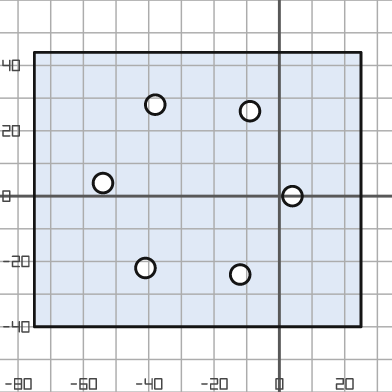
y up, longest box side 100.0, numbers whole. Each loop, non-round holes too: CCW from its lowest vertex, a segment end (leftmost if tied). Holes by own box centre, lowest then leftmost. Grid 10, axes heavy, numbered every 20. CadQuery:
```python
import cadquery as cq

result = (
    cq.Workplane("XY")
    .moveTo(-75.0, -40.0)
    .lineTo(25.0, -40.0)
    .lineTo(25.0, 44.0)
    .lineTo(-75.0, 44.0)
    .close()
    .moveTo(-12.0, -24.0)
    .circle(3.0)
    .moveTo(-41.0, -22.0)
    .circle(3.0)
    .moveTo(4.0, 0.0)
    .circle(3.0)
    .moveTo(-54.0, 4.0)
    .circle(3.0)
    .moveTo(-9.0, 26.0)
    .circle(3.0)
    .moveTo(-38.0, 28.0)
    .circle(3.0)
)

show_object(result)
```